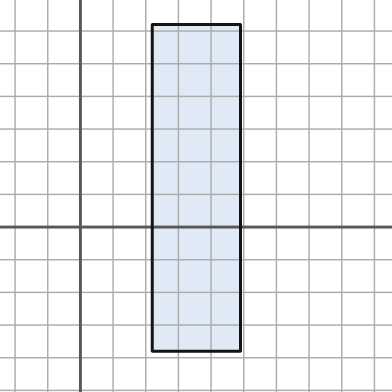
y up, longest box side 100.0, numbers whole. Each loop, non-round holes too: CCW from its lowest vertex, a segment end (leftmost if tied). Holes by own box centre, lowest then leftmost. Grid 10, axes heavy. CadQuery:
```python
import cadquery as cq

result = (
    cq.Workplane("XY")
    .moveTo(22.0, -38.0)
    .lineTo(49.0, -38.0)
    .lineTo(49.0, 62.0)
    .lineTo(22.0, 62.0)
    .close()
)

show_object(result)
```